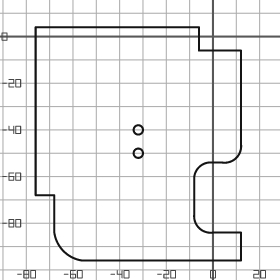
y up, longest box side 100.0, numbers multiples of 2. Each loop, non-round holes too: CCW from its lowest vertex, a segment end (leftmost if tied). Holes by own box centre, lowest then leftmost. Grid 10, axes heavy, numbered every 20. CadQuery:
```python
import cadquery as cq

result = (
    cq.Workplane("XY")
    .moveTo(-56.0, -96.0)
    .lineTo(12.0, -96.0)
    .lineTo(12.0, -84.0)
    .lineTo(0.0, -84.0)
    .threePointArc((-6.0, -82.0), (-8.0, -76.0))
    .lineTo(-8.0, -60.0)
    .threePointArc((-6.0, -56.0), (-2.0, -54.0))
    .lineTo(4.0, -54.0)
    .threePointArc((10.0, -52.0), (12.0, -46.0))
    .lineTo(12.0, -6.0)
    .lineTo(-6.0, -6.0)
    .lineTo(-6.0, 4.0)
    .lineTo(-76.0, 4.0)
    .lineTo(-76.0, -68.0)
    .lineTo(-68.0, -68.0)
    .lineTo(-68.0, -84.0)
    .threePointArc((-64.0, -92.0), (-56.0, -96.0))
    .close()
    .moveTo(-32.0, -50.0)
    .circle(2.0)
    .moveTo(-32.0, -40.0)
    .circle(2.0)
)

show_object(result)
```